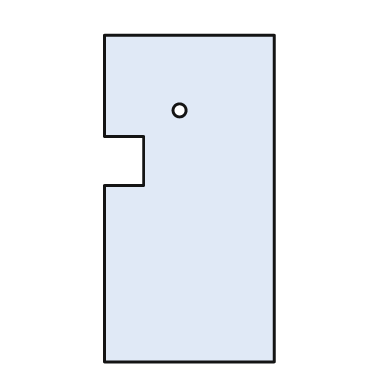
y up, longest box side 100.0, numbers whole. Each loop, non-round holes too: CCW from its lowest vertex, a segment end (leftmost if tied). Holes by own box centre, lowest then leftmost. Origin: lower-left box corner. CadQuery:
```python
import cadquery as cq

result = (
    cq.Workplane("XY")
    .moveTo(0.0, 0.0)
    .lineTo(52.0, 0.0)
    .lineTo(52.0, 100.0)
    .lineTo(0.0, 100.0)
    .lineTo(0.0, 69.0)
    .lineTo(12.0, 69.0)
    .lineTo(12.0, 54.0)
    .lineTo(0.0, 54.0)
    .close()
    .moveTo(23.0, 77.0)
    .circle(2.0)
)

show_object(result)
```